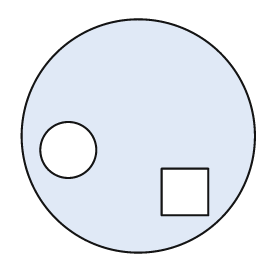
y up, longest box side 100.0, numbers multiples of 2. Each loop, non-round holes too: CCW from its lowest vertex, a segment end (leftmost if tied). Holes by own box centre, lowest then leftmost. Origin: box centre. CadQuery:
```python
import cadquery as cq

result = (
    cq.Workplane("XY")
    .moveTo(0.0, 0.0)
    .circle(50.0)
    .moveTo(10.0, -34.0)
    .lineTo(30.0, -34.0)
    .lineTo(30.0, -14.0)
    .lineTo(10.0, -14.0)
    .close()
    .moveTo(-30.0, -6.0)
    .circle(12.0)
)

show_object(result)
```